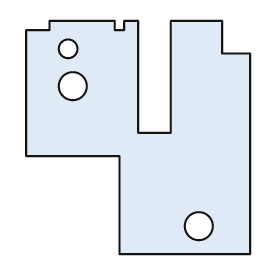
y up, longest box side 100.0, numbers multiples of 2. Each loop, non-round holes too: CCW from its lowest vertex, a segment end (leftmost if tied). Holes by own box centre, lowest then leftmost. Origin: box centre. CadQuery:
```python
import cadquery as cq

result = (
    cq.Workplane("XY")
    .moveTo(-8.0, -50.0)
    .lineTo(48.0, -50.0)
    .lineTo(48.0, 36.0)
    .lineTo(36.0, 36.0)
    .lineTo(36.0, 50.0)
    .lineTo(14.0, 50.0)
    .lineTo(14.0, 2.0)
    .lineTo(0.0, 2.0)
    .lineTo(0.0, 50.0)
    .lineTo(-6.0, 50.0)
    .lineTo(-6.0, 46.0)
    .lineTo(-10.0, 46.0)
    .lineTo(-10.0, 50.0)
    .lineTo(-38.0, 50.0)
    .lineTo(-38.0, 46.0)
    .lineTo(-48.0, 46.0)
    .lineTo(-48.0, -8.0)
    .lineTo(-8.0, -8.0)
    .close()
    .moveTo(26.0, -38.0)
    .circle(6.0)
    .moveTo(-28.0, 22.0)
    .circle(6.0)
    .moveTo(-30.0, 38.0)
    .circle(4.0)
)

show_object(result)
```